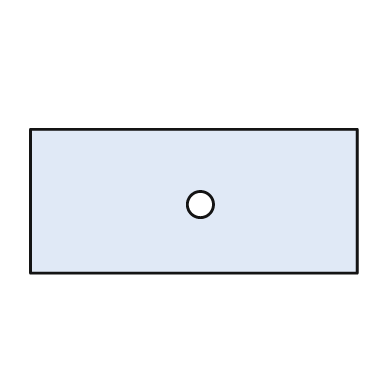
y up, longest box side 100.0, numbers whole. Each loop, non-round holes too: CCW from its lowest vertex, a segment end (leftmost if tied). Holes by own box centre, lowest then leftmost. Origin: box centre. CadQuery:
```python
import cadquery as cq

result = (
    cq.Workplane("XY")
    .moveTo(-50.0, -22.0)
    .lineTo(50.0, -22.0)
    .lineTo(50.0, 22.0)
    .lineTo(-50.0, 22.0)
    .close()
    .moveTo(2.0, -1.0)
    .circle(4.0)
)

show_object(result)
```